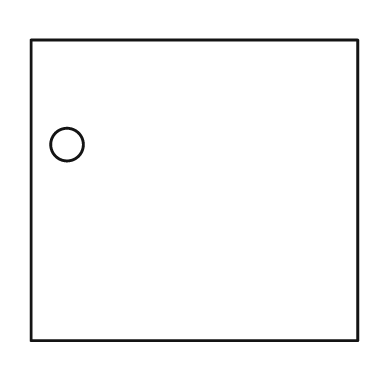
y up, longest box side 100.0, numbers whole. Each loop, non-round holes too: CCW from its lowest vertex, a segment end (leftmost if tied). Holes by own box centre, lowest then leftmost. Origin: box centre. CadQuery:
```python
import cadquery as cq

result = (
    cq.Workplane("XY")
    .moveTo(-50.0, -46.0)
    .lineTo(50.0, -46.0)
    .lineTo(50.0, 46.0)
    .lineTo(-50.0, 46.0)
    .close()
    .moveTo(-39.0, 14.0)
    .circle(5.0)
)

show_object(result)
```